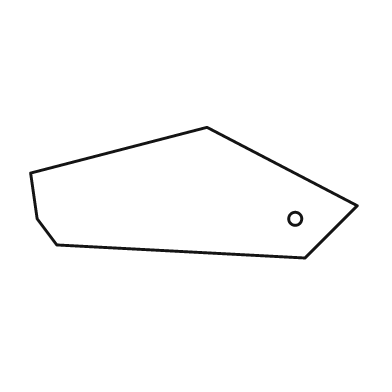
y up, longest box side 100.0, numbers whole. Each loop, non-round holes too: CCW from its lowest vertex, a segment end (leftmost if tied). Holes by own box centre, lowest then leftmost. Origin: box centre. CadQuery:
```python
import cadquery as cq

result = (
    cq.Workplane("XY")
    .moveTo(34.0, -20.0)
    .lineTo(50.0, -4.0)
    .lineTo(4.0, 20.0)
    .lineTo(-50.0, 6.0)
    .lineTo(-48.0, -8.0)
    .lineTo(-42.0, -16.0)
    .close()
    .moveTo(31.0, -8.0)
    .circle(2.0)
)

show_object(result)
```